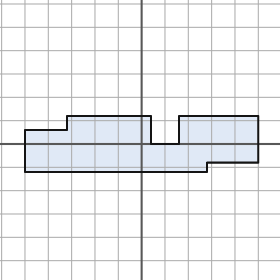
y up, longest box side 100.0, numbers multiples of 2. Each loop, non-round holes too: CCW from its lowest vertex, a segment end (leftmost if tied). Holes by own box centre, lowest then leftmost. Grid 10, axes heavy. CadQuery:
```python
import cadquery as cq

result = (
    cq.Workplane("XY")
    .moveTo(-50.0, -12.0)
    .lineTo(28.0, -12.0)
    .lineTo(28.0, -8.0)
    .lineTo(50.0, -8.0)
    .lineTo(50.0, 12.0)
    .lineTo(16.0, 12.0)
    .lineTo(16.0, 0.0)
    .lineTo(4.0, 0.0)
    .lineTo(4.0, 12.0)
    .lineTo(-32.0, 12.0)
    .lineTo(-32.0, 6.0)
    .lineTo(-50.0, 6.0)
    .close()
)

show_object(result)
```